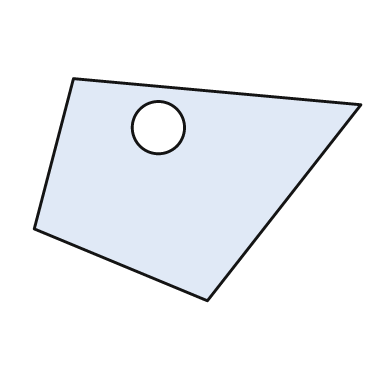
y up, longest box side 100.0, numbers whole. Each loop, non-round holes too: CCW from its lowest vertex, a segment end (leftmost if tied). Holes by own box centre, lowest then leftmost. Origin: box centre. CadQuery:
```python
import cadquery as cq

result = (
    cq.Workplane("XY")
    .moveTo(3.0, -34.0)
    .lineTo(50.0, 26.0)
    .lineTo(-38.0, 34.0)
    .lineTo(-50.0, -12.0)
    .close()
    .moveTo(-12.0, 19.0)
    .circle(8.0)
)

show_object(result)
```